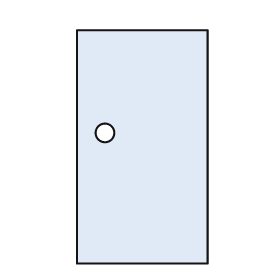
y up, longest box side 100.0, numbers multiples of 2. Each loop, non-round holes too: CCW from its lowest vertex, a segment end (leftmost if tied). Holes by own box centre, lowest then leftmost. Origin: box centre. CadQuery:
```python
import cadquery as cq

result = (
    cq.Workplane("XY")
    .moveTo(-28.0, -50.0)
    .lineTo(28.0, -50.0)
    .lineTo(28.0, 50.0)
    .lineTo(-28.0, 50.0)
    .close()
    .moveTo(-16.0, 6.0)
    .circle(4.0)
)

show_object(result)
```